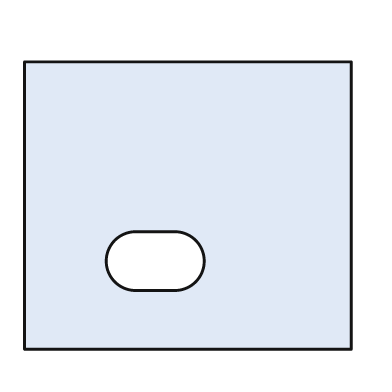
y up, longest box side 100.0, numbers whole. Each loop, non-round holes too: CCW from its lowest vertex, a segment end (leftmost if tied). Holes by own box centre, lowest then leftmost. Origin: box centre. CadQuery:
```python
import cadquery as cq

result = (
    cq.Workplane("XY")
    .moveTo(-50.0, -44.0)
    .lineTo(50.0, -44.0)
    .lineTo(50.0, 44.0)
    .lineTo(-50.0, 44.0)
    .close()
    .moveTo(-16.0, -26.0)
    .lineTo(-4.0, -26.0)
    .threePointArc((5.0, -17.0), (-4.0, -8.0))
    .lineTo(-16.0, -8.0)
    .threePointArc((-25.0, -17.0), (-16.0, -26.0))
    .close()
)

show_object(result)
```